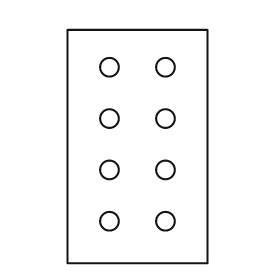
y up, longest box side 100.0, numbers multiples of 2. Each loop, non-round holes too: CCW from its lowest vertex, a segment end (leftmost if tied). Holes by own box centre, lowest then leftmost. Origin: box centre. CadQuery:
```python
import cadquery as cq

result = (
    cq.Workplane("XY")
    .moveTo(-30.0, -50.0)
    .lineTo(30.0, -50.0)
    .lineTo(30.0, 50.0)
    .lineTo(-30.0, 50.0)
    .close()
    .moveTo(-12.0, -32.0)
    .circle(4.0)
    .moveTo(12.0, -32.0)
    .circle(4.0)
    .moveTo(-12.0, -10.0)
    .circle(4.0)
    .moveTo(12.0, -10.0)
    .circle(4.0)
    .moveTo(-12.0, 12.0)
    .circle(4.0)
    .moveTo(12.0, 12.0)
    .circle(4.0)
    .moveTo(-12.0, 34.0)
    .circle(4.0)
    .moveTo(12.0, 34.0)
    .circle(4.0)
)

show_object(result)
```